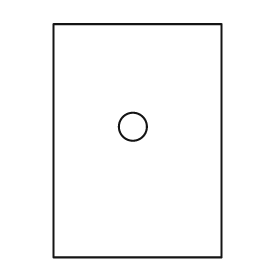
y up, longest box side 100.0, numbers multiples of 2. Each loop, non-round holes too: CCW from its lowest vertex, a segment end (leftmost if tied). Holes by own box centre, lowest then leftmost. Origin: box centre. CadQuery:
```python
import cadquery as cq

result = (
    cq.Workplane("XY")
    .moveTo(-36.0, -50.0)
    .lineTo(36.0, -50.0)
    .lineTo(36.0, 50.0)
    .lineTo(-36.0, 50.0)
    .close()
    .moveTo(-2.0, 6.0)
    .circle(6.0)
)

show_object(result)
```